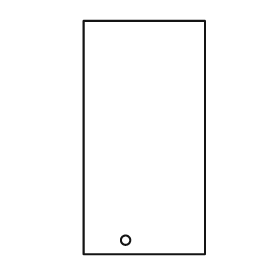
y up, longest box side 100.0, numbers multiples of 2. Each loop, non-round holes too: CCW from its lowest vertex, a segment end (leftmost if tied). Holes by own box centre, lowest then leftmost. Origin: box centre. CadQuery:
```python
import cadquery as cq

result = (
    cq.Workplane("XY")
    .moveTo(-26.0, -50.0)
    .lineTo(26.0, -50.0)
    .lineTo(26.0, 50.0)
    .lineTo(-26.0, 50.0)
    .close()
    .moveTo(-8.0, -44.0)
    .circle(2.0)
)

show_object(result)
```